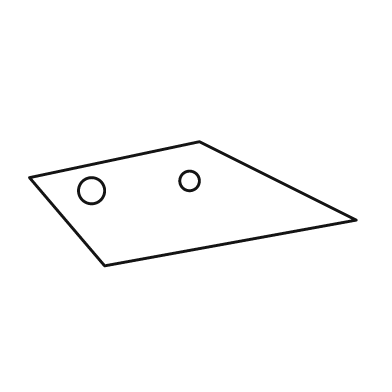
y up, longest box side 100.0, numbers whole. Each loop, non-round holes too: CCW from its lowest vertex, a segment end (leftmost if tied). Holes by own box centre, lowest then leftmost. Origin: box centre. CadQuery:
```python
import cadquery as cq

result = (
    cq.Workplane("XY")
    .moveTo(-27.0, -19.0)
    .lineTo(50.0, -5.0)
    .lineTo(2.0, 19.0)
    .lineTo(-50.0, 8.0)
    .close()
    .moveTo(-31.0, 4.0)
    .circle(4.0)
    .moveTo(-1.0, 7.0)
    .circle(3.0)
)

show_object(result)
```